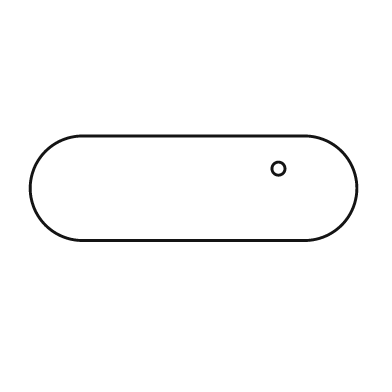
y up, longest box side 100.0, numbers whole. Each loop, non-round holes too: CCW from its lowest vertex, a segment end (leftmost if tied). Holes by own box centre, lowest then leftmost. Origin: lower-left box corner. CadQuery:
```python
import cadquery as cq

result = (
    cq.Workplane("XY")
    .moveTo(16.0, 0.0)
    .lineTo(84.0, 0.0)
    .threePointArc((100.0, 16.0), (84.0, 32.0))
    .lineTo(16.0, 32.0)
    .threePointArc((0.0, 16.0), (16.0, 0.0))
    .close()
    .moveTo(76.0, 22.0)
    .circle(2.0)
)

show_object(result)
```